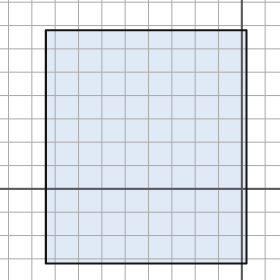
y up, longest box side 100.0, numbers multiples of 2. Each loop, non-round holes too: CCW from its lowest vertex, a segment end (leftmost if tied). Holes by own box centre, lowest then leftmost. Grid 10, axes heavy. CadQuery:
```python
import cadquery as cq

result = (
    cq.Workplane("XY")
    .moveTo(-84.0, -32.0)
    .lineTo(2.0, -32.0)
    .lineTo(2.0, 68.0)
    .lineTo(-84.0, 68.0)
    .close()
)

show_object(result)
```